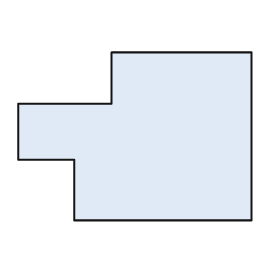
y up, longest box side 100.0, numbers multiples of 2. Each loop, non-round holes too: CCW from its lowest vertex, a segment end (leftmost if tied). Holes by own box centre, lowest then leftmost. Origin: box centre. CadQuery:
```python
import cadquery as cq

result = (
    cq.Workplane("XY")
    .moveTo(-26.0, -36.0)
    .lineTo(50.0, -36.0)
    .lineTo(50.0, 36.0)
    .lineTo(-10.0, 36.0)
    .lineTo(-10.0, 14.0)
    .lineTo(-50.0, 14.0)
    .lineTo(-50.0, -10.0)
    .lineTo(-26.0, -10.0)
    .close()
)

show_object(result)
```